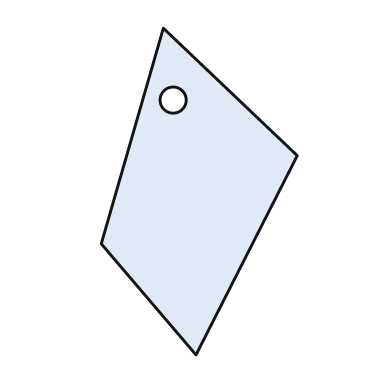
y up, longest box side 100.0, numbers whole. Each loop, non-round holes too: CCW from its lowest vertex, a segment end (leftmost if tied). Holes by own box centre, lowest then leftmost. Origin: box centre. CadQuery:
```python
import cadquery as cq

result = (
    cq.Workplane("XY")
    .moveTo(-1.0, -50.0)
    .lineTo(30.0, 11.0)
    .lineTo(-11.0, 50.0)
    .lineTo(-30.0, -16.0)
    .close()
    .moveTo(-8.0, 28.0)
    .circle(4.0)
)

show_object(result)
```